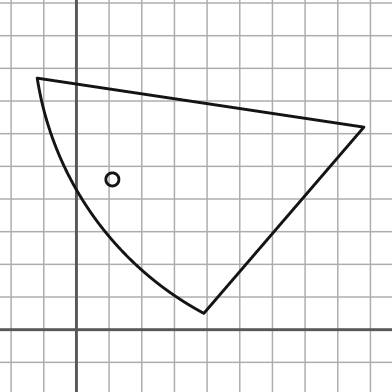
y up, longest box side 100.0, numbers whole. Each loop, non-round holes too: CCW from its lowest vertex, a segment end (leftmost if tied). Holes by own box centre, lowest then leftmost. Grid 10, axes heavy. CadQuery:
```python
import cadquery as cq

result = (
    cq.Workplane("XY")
    .moveTo(39.0, 5.0)
    .lineTo(88.0, 62.0)
    .lineTo(-12.0, 77.0)
    .threePointArc((5.0, 35.0), (39.0, 5.0))
    .close()
    .moveTo(11.0, 46.0)
    .circle(2.0)
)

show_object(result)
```